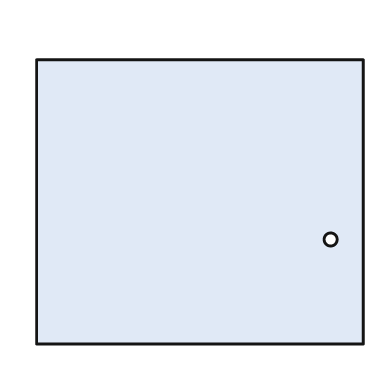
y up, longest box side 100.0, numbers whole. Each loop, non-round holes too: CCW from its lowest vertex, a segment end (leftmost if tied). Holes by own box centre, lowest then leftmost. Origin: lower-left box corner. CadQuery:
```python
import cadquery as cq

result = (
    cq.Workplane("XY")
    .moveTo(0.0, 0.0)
    .lineTo(100.0, 0.0)
    .lineTo(100.0, 87.0)
    .lineTo(0.0, 87.0)
    .close()
    .moveTo(90.0, 32.0)
    .circle(2.0)
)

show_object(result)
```